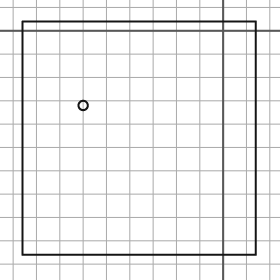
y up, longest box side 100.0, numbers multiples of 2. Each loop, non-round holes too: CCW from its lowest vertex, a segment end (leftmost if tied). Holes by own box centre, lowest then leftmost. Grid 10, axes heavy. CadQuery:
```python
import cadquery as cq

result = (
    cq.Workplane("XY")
    .moveTo(-86.0, -96.0)
    .lineTo(14.0, -96.0)
    .lineTo(14.0, 4.0)
    .lineTo(-86.0, 4.0)
    .close()
    .moveTo(-60.0, -32.0)
    .circle(2.0)
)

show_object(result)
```